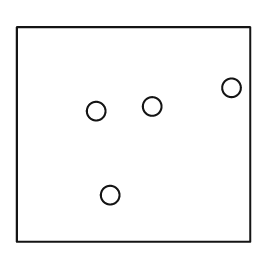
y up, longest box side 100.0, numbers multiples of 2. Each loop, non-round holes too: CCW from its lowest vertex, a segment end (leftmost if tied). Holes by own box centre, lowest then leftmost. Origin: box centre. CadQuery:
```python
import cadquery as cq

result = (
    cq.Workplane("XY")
    .moveTo(-50.0, -46.0)
    .lineTo(50.0, -46.0)
    .lineTo(50.0, 46.0)
    .lineTo(-50.0, 46.0)
    .close()
    .moveTo(-10.0, -26.0)
    .circle(4.0)
    .moveTo(-16.0, 10.0)
    .circle(4.0)
    .moveTo(8.0, 12.0)
    .circle(4.0)
    .moveTo(42.0, 20.0)
    .circle(4.0)
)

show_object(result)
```